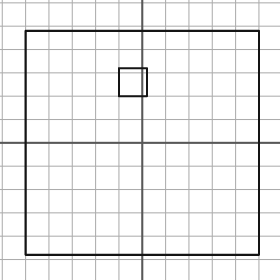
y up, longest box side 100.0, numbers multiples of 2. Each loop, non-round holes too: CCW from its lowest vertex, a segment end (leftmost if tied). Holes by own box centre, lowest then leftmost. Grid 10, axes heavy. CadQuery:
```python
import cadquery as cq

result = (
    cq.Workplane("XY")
    .moveTo(-50.0, -48.0)
    .lineTo(50.0, -48.0)
    .lineTo(50.0, 48.0)
    .lineTo(-50.0, 48.0)
    .close()
    .moveTo(-10.0, 20.0)
    .lineTo(2.0, 20.0)
    .lineTo(2.0, 32.0)
    .lineTo(-10.0, 32.0)
    .close()
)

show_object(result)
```